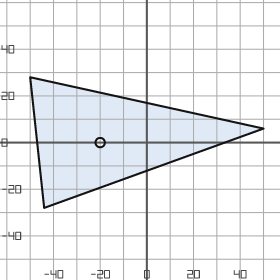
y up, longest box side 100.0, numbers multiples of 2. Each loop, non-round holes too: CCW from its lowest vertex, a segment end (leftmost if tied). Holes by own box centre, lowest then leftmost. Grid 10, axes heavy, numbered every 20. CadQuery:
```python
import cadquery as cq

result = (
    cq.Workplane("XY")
    .moveTo(-44.0, -28.0)
    .lineTo(50.0, 6.0)
    .lineTo(-50.0, 28.0)
    .close()
    .moveTo(-20.0, 0.0)
    .circle(2.0)
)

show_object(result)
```